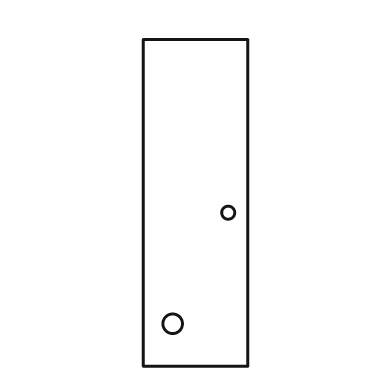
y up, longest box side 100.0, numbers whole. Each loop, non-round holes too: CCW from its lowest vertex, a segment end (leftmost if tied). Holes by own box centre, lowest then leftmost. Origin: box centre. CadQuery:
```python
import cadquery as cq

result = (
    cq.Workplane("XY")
    .moveTo(-16.0, -50.0)
    .lineTo(16.0, -50.0)
    .lineTo(16.0, 50.0)
    .lineTo(-16.0, 50.0)
    .close()
    .moveTo(-7.0, -37.0)
    .circle(3.0)
    .moveTo(10.0, -3.0)
    .circle(2.0)
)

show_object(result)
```